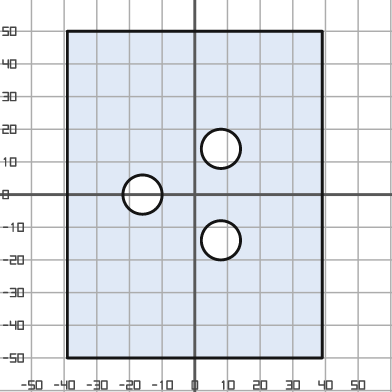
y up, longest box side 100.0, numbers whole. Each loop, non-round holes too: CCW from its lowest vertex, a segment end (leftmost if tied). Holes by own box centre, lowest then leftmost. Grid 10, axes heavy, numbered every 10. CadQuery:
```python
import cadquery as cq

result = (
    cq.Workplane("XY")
    .moveTo(-39.0, -50.0)
    .lineTo(39.0, -50.0)
    .lineTo(39.0, 50.0)
    .lineTo(-39.0, 50.0)
    .close()
    .moveTo(8.0, -14.0)
    .circle(6.0)
    .moveTo(-16.0, 0.0)
    .circle(6.0)
    .moveTo(8.0, 14.0)
    .circle(6.0)
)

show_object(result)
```